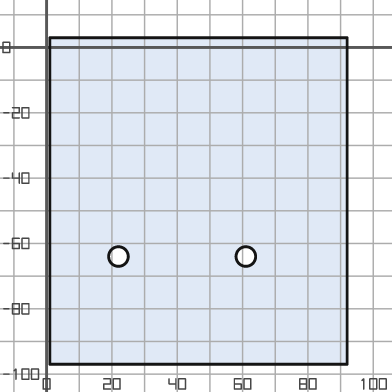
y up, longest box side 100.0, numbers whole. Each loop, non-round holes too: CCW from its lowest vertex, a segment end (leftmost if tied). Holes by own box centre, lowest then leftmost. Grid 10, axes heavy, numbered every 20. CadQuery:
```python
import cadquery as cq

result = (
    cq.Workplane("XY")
    .moveTo(1.0, -97.0)
    .lineTo(92.0, -97.0)
    .lineTo(92.0, 3.0)
    .lineTo(1.0, 3.0)
    .close()
    .moveTo(22.0, -64.0)
    .circle(3.0)
    .moveTo(61.0, -64.0)
    .circle(3.0)
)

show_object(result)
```